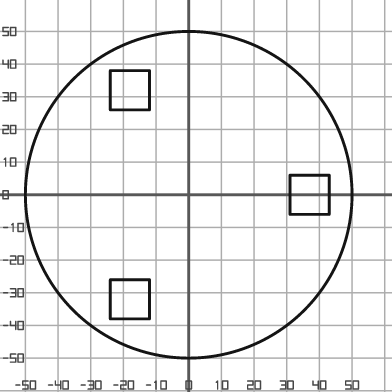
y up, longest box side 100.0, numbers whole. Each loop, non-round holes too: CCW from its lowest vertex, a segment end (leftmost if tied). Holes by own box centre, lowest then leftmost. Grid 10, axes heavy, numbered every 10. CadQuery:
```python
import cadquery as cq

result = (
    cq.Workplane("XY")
    .moveTo(0.0, 0.0)
    .circle(50.0)
    .moveTo(-24.0, -38.0)
    .lineTo(-12.0, -38.0)
    .lineTo(-12.0, -26.0)
    .lineTo(-24.0, -26.0)
    .close()
    .moveTo(31.0, -6.0)
    .lineTo(43.0, -6.0)
    .lineTo(43.0, 6.0)
    .lineTo(31.0, 6.0)
    .close()
    .moveTo(-24.0, 26.0)
    .lineTo(-12.0, 26.0)
    .lineTo(-12.0, 38.0)
    .lineTo(-24.0, 38.0)
    .close()
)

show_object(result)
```